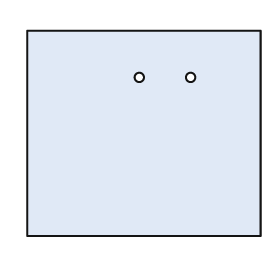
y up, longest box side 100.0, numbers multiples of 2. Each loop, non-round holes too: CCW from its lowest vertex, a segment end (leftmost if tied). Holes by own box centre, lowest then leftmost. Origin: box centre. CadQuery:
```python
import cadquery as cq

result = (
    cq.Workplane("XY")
    .moveTo(-50.0, -44.0)
    .lineTo(50.0, -44.0)
    .lineTo(50.0, 44.0)
    .lineTo(-50.0, 44.0)
    .close()
    .moveTo(-2.0, 24.0)
    .circle(2.0)
    .moveTo(20.0, 24.0)
    .circle(2.0)
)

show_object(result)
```